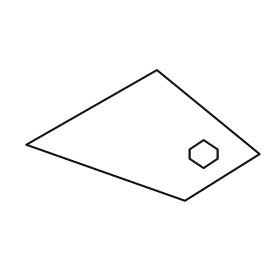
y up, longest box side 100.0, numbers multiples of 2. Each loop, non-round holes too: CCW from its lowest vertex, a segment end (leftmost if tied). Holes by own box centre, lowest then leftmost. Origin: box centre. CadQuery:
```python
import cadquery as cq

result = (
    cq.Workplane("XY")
    .moveTo(18.0, -28.0)
    .lineTo(50.0, -8.0)
    .lineTo(6.0, 28.0)
    .lineTo(-50.0, -4.0)
    .close()
    .moveTo(26.0, -14.0)
    .lineTo(32.0, -10.0)
    .lineTo(32.0, -6.0)
    .lineTo(26.0, -2.0)
    .lineTo(20.0, -6.0)
    .lineTo(20.0, -10.0)
    .close()
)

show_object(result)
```